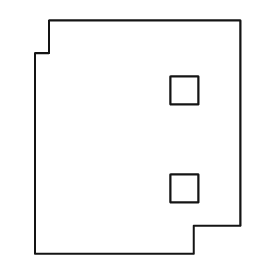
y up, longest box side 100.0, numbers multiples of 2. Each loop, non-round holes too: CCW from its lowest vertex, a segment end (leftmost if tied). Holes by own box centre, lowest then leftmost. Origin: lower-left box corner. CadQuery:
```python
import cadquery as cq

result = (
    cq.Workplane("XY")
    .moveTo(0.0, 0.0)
    .lineTo(68.0, 0.0)
    .lineTo(68.0, 12.0)
    .lineTo(88.0, 12.0)
    .lineTo(88.0, 100.0)
    .lineTo(6.0, 100.0)
    .lineTo(6.0, 86.0)
    .lineTo(0.0, 86.0)
    .close()
    .moveTo(58.0, 22.0)
    .lineTo(70.0, 22.0)
    .lineTo(70.0, 34.0)
    .lineTo(58.0, 34.0)
    .close()
    .moveTo(58.0, 64.0)
    .lineTo(70.0, 64.0)
    .lineTo(70.0, 76.0)
    .lineTo(58.0, 76.0)
    .close()
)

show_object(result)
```